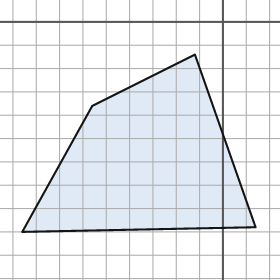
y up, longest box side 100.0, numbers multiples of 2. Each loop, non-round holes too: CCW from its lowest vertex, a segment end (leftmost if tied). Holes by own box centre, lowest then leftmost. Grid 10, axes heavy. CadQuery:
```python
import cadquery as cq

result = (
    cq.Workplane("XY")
    .moveTo(-86.0, -90.0)
    .lineTo(14.0, -88.0)
    .lineTo(-12.0, -14.0)
    .lineTo(-56.0, -36.0)
    .close()
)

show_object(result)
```